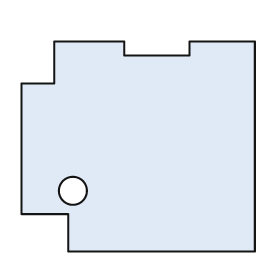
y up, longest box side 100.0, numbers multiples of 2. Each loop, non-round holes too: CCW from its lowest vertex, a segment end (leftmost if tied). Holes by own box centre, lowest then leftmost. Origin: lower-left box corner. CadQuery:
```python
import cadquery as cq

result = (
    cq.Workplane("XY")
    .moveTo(20.0, 0.0)
    .lineTo(100.0, 0.0)
    .lineTo(100.0, 90.0)
    .lineTo(72.0, 90.0)
    .lineTo(72.0, 84.0)
    .lineTo(44.0, 84.0)
    .lineTo(44.0, 90.0)
    .lineTo(14.0, 90.0)
    .lineTo(14.0, 72.0)
    .lineTo(0.0, 72.0)
    .lineTo(0.0, 16.0)
    .lineTo(20.0, 16.0)
    .close()
    .moveTo(22.0, 26.0)
    .circle(6.0)
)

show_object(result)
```